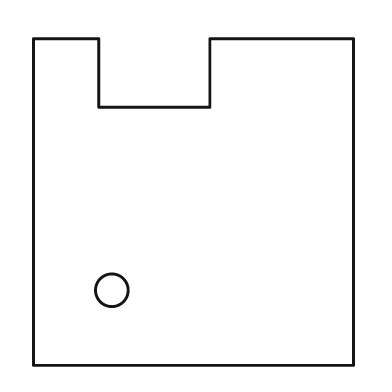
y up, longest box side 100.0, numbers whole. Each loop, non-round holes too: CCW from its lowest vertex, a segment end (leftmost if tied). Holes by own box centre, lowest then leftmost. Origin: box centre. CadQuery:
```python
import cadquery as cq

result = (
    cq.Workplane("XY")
    .moveTo(-49.0, -50.0)
    .lineTo(49.0, -50.0)
    .lineTo(49.0, 50.0)
    .lineTo(5.0, 50.0)
    .lineTo(5.0, 29.0)
    .lineTo(-29.0, 29.0)
    .lineTo(-29.0, 50.0)
    .lineTo(-49.0, 50.0)
    .close()
    .moveTo(-25.0, -27.0)
    .circle(5.0)
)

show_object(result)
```